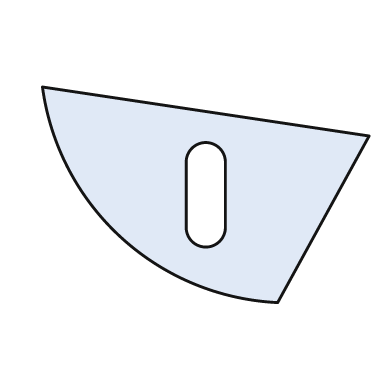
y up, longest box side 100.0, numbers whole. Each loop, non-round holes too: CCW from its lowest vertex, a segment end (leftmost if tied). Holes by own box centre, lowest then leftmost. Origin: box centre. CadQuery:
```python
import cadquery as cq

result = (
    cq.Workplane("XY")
    .moveTo(22.0, -33.0)
    .lineTo(50.0, 18.0)
    .lineTo(-50.0, 33.0)
    .threePointArc((-26.0, -13.0), (22.0, -33.0))
    .close()
    .moveTo(-6.0, -10.0)
    .threePointArc((0.0, -16.0), (6.0, -10.0))
    .lineTo(6.0, 10.0)
    .threePointArc((0.0, 16.0), (-6.0, 10.0))
    .close()
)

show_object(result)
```